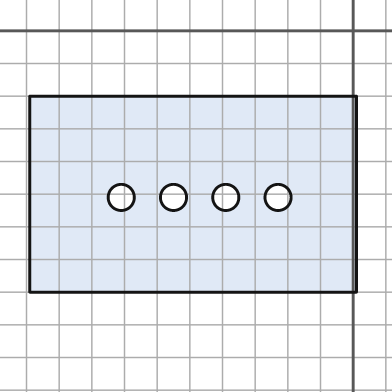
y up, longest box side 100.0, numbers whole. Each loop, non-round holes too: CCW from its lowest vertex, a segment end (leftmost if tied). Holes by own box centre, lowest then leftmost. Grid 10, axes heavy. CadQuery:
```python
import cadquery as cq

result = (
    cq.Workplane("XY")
    .moveTo(-99.0, -80.0)
    .lineTo(1.0, -80.0)
    .lineTo(1.0, -20.0)
    .lineTo(-99.0, -20.0)
    .close()
    .moveTo(-71.0, -51.0)
    .circle(4.0)
    .moveTo(-55.0, -51.0)
    .circle(4.0)
    .moveTo(-39.0, -51.0)
    .circle(4.0)
    .moveTo(-23.0, -51.0)
    .circle(4.0)
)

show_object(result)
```